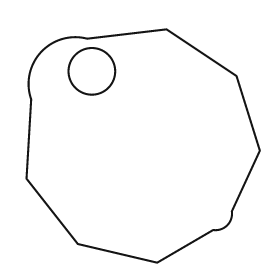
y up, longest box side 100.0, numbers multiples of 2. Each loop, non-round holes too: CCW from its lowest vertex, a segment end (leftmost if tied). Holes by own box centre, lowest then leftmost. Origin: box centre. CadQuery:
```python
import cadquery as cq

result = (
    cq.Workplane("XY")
    .moveTo(6.0, -50.0)
    .lineTo(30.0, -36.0)
    .threePointArc((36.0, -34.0), (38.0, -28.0))
    .lineTo(50.0, -2.0)
    .lineTo(40.0, 30.0)
    .lineTo(10.0, 50.0)
    .lineTo(-24.0, 46.0)
    .threePointArc((-44.0, 40.0), (-48.0, 20.0))
    .lineTo(-50.0, -14.0)
    .lineTo(-28.0, -42.0)
    .close()
    .moveTo(-22.0, 32.0)
    .circle(10.0)
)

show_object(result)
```